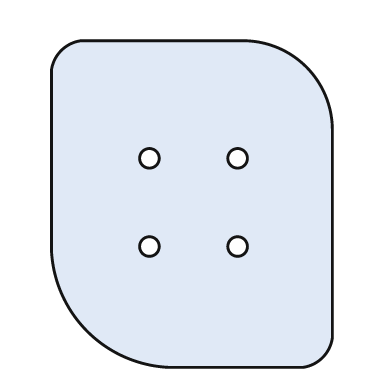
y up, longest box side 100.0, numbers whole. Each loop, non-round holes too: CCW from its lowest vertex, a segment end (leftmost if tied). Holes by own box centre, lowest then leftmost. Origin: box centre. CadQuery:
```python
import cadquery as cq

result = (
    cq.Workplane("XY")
    .moveTo(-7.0, -50.0)
    .lineTo(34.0, -50.0)
    .threePointArc((40.0, -47.0), (43.0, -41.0))
    .lineTo(43.0, 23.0)
    .threePointArc((35.0, 42.0), (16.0, 50.0))
    .lineTo(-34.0, 50.0)
    .threePointArc((-40.0, 47.0), (-43.0, 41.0))
    .lineTo(-43.0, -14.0)
    .threePointArc((-32.0, -39.0), (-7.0, -50.0))
    .close()
    .moveTo(-13.0, -13.0)
    .circle(3.0)
    .moveTo(14.0, -13.0)
    .circle(3.0)
    .moveTo(-13.0, 14.0)
    .circle(3.0)
    .moveTo(14.0, 14.0)
    .circle(3.0)
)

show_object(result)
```